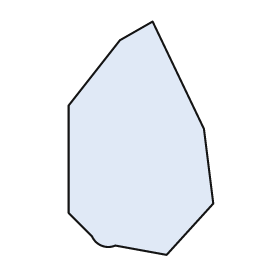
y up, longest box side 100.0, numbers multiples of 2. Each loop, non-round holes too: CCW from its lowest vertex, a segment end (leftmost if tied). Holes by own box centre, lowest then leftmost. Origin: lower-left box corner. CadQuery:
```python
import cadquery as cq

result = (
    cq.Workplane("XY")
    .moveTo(42.0, 0.0)
    .lineTo(62.0, 22.0)
    .lineTo(58.0, 54.0)
    .lineTo(36.0, 100.0)
    .lineTo(22.0, 92.0)
    .lineTo(0.0, 64.0)
    .lineTo(0.0, 18.0)
    .lineTo(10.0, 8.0)
    .threePointArc((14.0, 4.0), (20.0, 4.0))
    .close()
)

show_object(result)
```